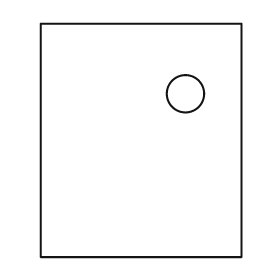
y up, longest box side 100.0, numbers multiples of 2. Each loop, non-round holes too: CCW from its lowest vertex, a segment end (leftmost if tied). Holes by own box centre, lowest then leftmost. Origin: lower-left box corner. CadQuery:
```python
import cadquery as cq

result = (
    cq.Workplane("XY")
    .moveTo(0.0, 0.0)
    .lineTo(86.0, 0.0)
    .lineTo(86.0, 100.0)
    .lineTo(0.0, 100.0)
    .close()
    .moveTo(62.0, 70.0)
    .circle(8.0)
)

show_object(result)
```